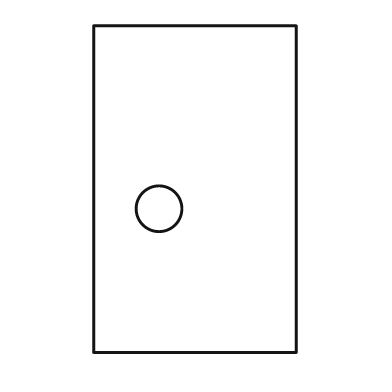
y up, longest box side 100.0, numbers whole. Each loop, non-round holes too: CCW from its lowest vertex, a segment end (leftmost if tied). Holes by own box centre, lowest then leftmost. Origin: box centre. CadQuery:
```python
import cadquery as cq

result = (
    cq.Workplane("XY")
    .moveTo(-31.0, -50.0)
    .lineTo(31.0, -50.0)
    .lineTo(31.0, 50.0)
    .lineTo(-31.0, 50.0)
    .close()
    .moveTo(-11.0, -6.0)
    .circle(7.0)
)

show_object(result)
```